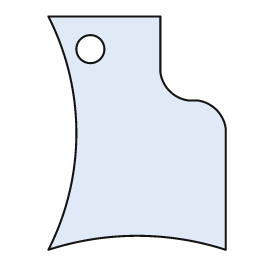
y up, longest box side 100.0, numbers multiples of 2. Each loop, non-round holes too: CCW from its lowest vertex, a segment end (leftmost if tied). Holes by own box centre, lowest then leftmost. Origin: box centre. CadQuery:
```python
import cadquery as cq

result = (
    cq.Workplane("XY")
    .moveTo(-38.0, -50.0)
    .threePointArc((0.0, -44.0), (38.0, -50.0))
    .lineTo(38.0, 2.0)
    .threePointArc((34.0, 10.0), (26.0, 14.0))
    .lineTo(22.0, 14.0)
    .threePointArc((14.0, 18.0), (10.0, 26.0))
    .lineTo(10.0, 50.0)
    .lineTo(-38.0, 50.0)
    .threePointArc((-26.0, 0.0), (-38.0, -50.0))
    .close()
    .moveTo(-20.0, 36.0)
    .circle(6.0)
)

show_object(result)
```